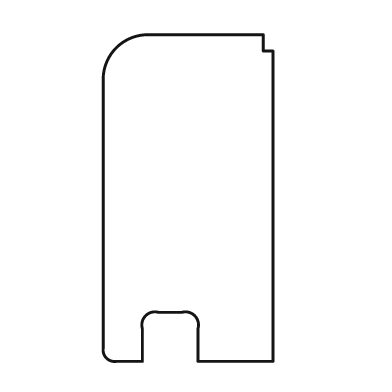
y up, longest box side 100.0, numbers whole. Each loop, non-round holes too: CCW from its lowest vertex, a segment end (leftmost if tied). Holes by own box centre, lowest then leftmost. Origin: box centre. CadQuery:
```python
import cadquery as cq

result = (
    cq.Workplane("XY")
    .moveTo(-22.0, -50.0)
    .lineTo(-14.0, -50.0)
    .lineTo(-14.0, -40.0)
    .threePointArc((-13.0, -36.0), (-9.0, -35.0))
    .lineTo(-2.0, -35.0)
    .threePointArc((2.0, -36.0), (3.0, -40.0))
    .lineTo(3.0, -50.0)
    .lineTo(26.0, -50.0)
    .lineTo(26.0, 45.0)
    .lineTo(23.0, 45.0)
    .lineTo(23.0, 50.0)
    .lineTo(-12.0, 50.0)
    .threePointArc((-22.0, 46.0), (-26.0, 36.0))
    .lineTo(-26.0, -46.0)
    .threePointArc((-25.0, -49.0), (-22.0, -50.0))
    .close()
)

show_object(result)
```